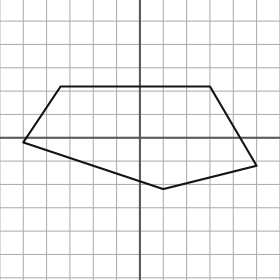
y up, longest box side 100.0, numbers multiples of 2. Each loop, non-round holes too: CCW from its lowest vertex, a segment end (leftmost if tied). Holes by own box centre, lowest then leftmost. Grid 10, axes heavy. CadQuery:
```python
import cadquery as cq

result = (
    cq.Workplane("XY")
    .moveTo(10.0, -22.0)
    .lineTo(50.0, -12.0)
    .lineTo(30.0, 22.0)
    .lineTo(-34.0, 22.0)
    .lineTo(-50.0, -2.0)
    .close()
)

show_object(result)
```